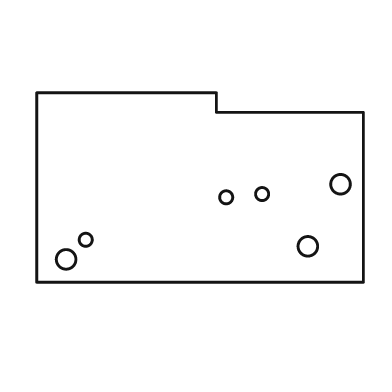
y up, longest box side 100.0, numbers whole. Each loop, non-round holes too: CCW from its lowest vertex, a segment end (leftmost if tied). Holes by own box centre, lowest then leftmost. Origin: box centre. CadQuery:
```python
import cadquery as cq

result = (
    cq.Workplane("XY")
    .moveTo(-50.0, -29.0)
    .lineTo(50.0, -29.0)
    .lineTo(50.0, 23.0)
    .lineTo(5.0, 23.0)
    .lineTo(5.0, 29.0)
    .lineTo(-50.0, 29.0)
    .close()
    .moveTo(-41.0, -22.0)
    .circle(3.0)
    .moveTo(33.0, -18.0)
    .circle(3.0)
    .moveTo(-35.0, -16.0)
    .circle(2.0)
    .moveTo(8.0, -3.0)
    .circle(2.0)
    .moveTo(19.0, -2.0)
    .circle(2.0)
    .moveTo(43.0, 1.0)
    .circle(3.0)
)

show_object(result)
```